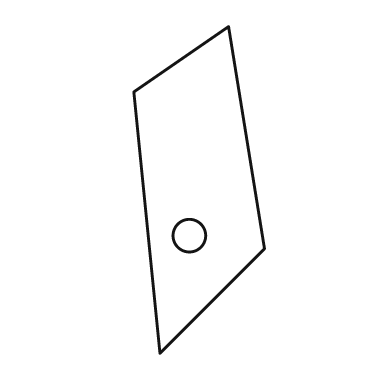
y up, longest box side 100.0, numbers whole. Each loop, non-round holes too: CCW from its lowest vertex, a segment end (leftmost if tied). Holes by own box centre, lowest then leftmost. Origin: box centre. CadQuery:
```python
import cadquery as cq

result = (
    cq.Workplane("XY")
    .moveTo(-12.0, -50.0)
    .lineTo(20.0, -18.0)
    .lineTo(9.0, 50.0)
    .lineTo(-20.0, 30.0)
    .close()
    .moveTo(-3.0, -14.0)
    .circle(5.0)
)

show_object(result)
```